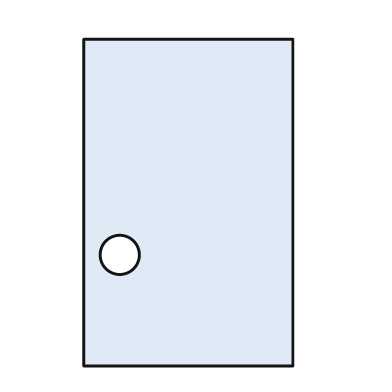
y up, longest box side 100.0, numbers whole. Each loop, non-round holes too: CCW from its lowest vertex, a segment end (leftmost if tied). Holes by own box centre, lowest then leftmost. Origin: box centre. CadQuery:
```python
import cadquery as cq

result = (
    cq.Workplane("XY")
    .moveTo(-32.0, -50.0)
    .lineTo(32.0, -50.0)
    .lineTo(32.0, 50.0)
    .lineTo(-32.0, 50.0)
    .close()
    .moveTo(-21.0, -16.0)
    .circle(6.0)
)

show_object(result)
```